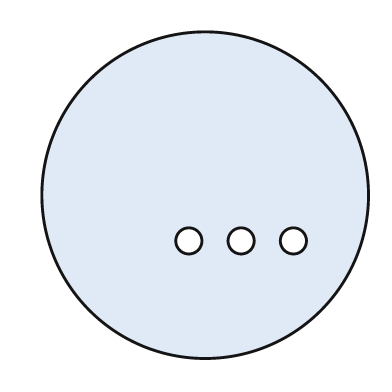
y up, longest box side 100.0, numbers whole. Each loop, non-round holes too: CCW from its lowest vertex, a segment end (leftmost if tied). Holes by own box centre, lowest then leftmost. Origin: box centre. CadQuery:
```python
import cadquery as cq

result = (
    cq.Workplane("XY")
    .moveTo(0.0, 0.0)
    .circle(50.0)
    .moveTo(-5.0, -14.0)
    .circle(4.0)
    .moveTo(11.0, -14.0)
    .circle(4.0)
    .moveTo(27.0, -14.0)
    .circle(4.0)
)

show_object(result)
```